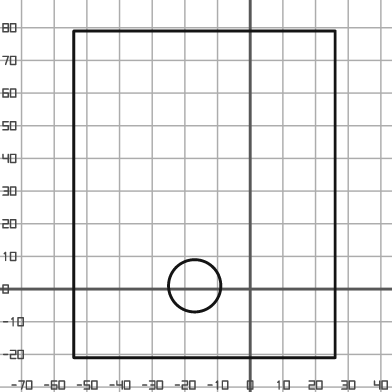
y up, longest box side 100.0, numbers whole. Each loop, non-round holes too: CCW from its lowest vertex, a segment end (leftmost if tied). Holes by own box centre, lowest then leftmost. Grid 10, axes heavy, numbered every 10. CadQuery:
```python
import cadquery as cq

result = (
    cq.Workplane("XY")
    .moveTo(-54.0, -21.0)
    .lineTo(26.0, -21.0)
    .lineTo(26.0, 79.0)
    .lineTo(-54.0, 79.0)
    .close()
    .moveTo(-17.0, 1.0)
    .circle(8.0)
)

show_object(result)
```